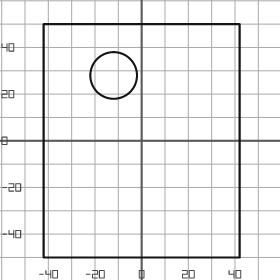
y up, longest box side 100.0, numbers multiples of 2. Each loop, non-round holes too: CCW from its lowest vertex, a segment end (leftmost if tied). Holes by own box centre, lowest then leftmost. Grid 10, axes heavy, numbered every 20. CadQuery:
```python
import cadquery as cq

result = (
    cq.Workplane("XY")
    .moveTo(-42.0, -50.0)
    .lineTo(42.0, -50.0)
    .lineTo(42.0, 50.0)
    .lineTo(-42.0, 50.0)
    .close()
    .moveTo(-12.0, 28.0)
    .circle(10.0)
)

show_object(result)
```